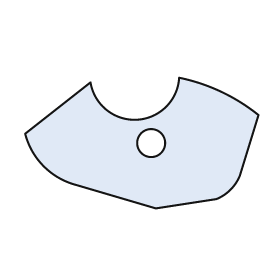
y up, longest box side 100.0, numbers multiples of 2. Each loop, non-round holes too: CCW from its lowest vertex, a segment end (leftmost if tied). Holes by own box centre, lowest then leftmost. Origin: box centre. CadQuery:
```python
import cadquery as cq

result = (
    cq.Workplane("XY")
    .moveTo(6.0, -28.0)
    .lineTo(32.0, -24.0)
    .threePointArc((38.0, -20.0), (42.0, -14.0))
    .lineTo(50.0, 12.0)
    .threePointArc((34.0, 22.0), (16.0, 28.0))
    .threePointArc((-2.0, 10.0), (-22.0, 26.0))
    .lineTo(-50.0, 4.0)
    .threePointArc((-42.0, -10.0), (-28.0, -18.0))
    .close()
    .moveTo(4.0, 0.0)
    .circle(6.0)
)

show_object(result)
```